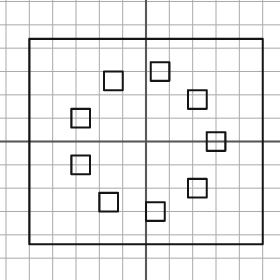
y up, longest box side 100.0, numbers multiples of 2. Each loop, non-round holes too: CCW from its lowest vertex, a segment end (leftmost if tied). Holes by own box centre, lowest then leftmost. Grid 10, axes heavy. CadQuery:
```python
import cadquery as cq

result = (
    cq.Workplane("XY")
    .moveTo(-50.0, -44.0)
    .lineTo(50.0, -44.0)
    .lineTo(50.0, 44.0)
    .lineTo(-50.0, 44.0)
    .close()
    .moveTo(0.0, -34.0)
    .lineTo(8.0, -34.0)
    .lineTo(8.0, -26.0)
    .lineTo(0.0, -26.0)
    .close()
    .moveTo(-20.0, -30.0)
    .lineTo(-12.0, -30.0)
    .lineTo(-12.0, -22.0)
    .lineTo(-20.0, -22.0)
    .close()
    .moveTo(18.0, -24.0)
    .lineTo(26.0, -24.0)
    .lineTo(26.0, -16.0)
    .lineTo(18.0, -16.0)
    .close()
    .moveTo(-32.0, -14.0)
    .lineTo(-24.0, -14.0)
    .lineTo(-24.0, -6.0)
    .lineTo(-32.0, -6.0)
    .close()
    .moveTo(26.0, -4.0)
    .lineTo(34.0, -4.0)
    .lineTo(34.0, 4.0)
    .lineTo(26.0, 4.0)
    .close()
    .moveTo(-32.0, 6.0)
    .lineTo(-24.0, 6.0)
    .lineTo(-24.0, 14.0)
    .lineTo(-32.0, 14.0)
    .close()
    .moveTo(18.0, 14.0)
    .lineTo(26.0, 14.0)
    .lineTo(26.0, 22.0)
    .lineTo(18.0, 22.0)
    .close()
    .moveTo(-18.0, 22.0)
    .lineTo(-10.0, 22.0)
    .lineTo(-10.0, 30.0)
    .lineTo(-18.0, 30.0)
    .close()
    .moveTo(2.0, 26.0)
    .lineTo(10.0, 26.0)
    .lineTo(10.0, 34.0)
    .lineTo(2.0, 34.0)
    .close()
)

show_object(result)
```